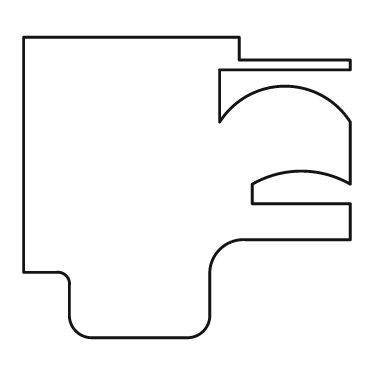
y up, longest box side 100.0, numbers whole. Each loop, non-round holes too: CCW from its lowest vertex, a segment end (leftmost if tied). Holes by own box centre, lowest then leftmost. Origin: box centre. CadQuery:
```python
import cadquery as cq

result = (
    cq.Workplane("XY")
    .moveTo(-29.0, -46.0)
    .lineTo(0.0, -46.0)
    .threePointArc((5.0, -44.0), (7.0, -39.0))
    .lineTo(7.0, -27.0)
    .threePointArc((10.0, -19.0), (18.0, -16.0))
    .lineTo(50.0, -16.0)
    .lineTo(50.0, -5.0)
    .lineTo(20.0, -5.0)
    .lineTo(20.0, 1.0)
    .threePointArc((35.0, 5.0), (50.0, 1.0))
    .lineTo(50.0, 20.0)
    .threePointArc((30.0, 31.0), (10.0, 20.0))
    .lineTo(10.0, 36.0)
    .lineTo(50.0, 36.0)
    .lineTo(50.0, 39.0)
    .lineTo(16.0, 39.0)
    .lineTo(16.0, 46.0)
    .lineTo(-50.0, 46.0)
    .lineTo(-50.0, -26.0)
    .lineTo(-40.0, -26.0)
    .threePointArc((-37.0, -27.0), (-36.0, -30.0))
    .lineTo(-36.0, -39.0)
    .threePointArc((-34.0, -44.0), (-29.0, -46.0))
    .close()
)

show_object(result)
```